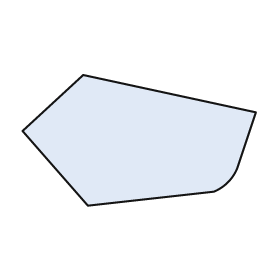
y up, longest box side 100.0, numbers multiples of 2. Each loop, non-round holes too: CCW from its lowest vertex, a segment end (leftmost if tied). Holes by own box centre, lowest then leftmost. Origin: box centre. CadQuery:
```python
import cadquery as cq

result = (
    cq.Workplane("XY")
    .moveTo(-22.0, -28.0)
    .lineTo(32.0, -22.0)
    .threePointArc((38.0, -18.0), (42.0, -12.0))
    .lineTo(50.0, 12.0)
    .lineTo(-24.0, 28.0)
    .lineTo(-50.0, 4.0)
    .close()
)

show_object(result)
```